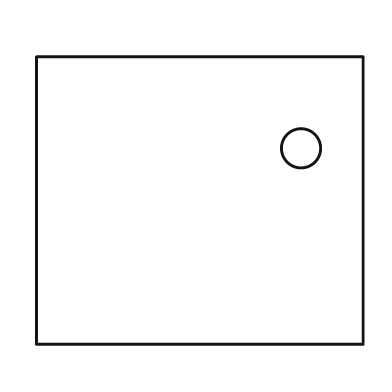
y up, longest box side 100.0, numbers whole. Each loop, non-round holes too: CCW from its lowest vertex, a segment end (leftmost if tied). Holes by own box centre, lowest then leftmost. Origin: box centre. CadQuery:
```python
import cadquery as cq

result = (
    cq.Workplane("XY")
    .moveTo(-50.0, -44.0)
    .lineTo(50.0, -44.0)
    .lineTo(50.0, 44.0)
    .lineTo(-50.0, 44.0)
    .close()
    .moveTo(31.0, 16.0)
    .circle(6.0)
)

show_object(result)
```